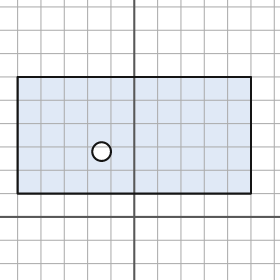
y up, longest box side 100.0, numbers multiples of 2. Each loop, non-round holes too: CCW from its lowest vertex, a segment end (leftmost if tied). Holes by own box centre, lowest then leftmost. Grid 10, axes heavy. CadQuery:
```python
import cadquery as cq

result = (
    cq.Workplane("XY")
    .moveTo(-50.0, 10.0)
    .lineTo(50.0, 10.0)
    .lineTo(50.0, 60.0)
    .lineTo(-50.0, 60.0)
    .close()
    .moveTo(-14.0, 28.0)
    .circle(4.0)
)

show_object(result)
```